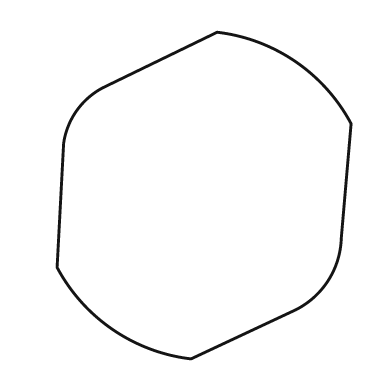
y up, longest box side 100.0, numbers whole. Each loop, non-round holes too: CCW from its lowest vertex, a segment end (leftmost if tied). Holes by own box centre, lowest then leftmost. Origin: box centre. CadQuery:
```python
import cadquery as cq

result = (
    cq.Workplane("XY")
    .moveTo(-4.0, -50.0)
    .lineTo(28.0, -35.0)
    .threePointArc((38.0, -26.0), (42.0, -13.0))
    .lineTo(45.0, 22.0)
    .threePointArc((28.0, 41.0), (4.0, 50.0))
    .lineTo(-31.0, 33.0)
    .threePointArc((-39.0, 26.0), (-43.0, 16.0))
    .lineTo(-45.0, -22.0)
    .threePointArc((-28.0, -41.0), (-4.0, -50.0))
    .close()
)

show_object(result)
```